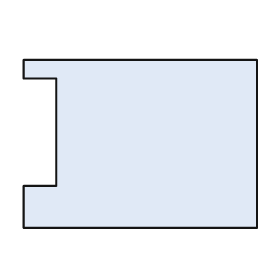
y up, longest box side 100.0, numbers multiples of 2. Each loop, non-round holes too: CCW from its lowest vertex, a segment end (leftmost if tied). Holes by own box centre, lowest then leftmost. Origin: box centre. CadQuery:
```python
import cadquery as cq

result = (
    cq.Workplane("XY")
    .moveTo(-50.0, -36.0)
    .lineTo(50.0, -36.0)
    .lineTo(50.0, 36.0)
    .lineTo(-50.0, 36.0)
    .lineTo(-50.0, 28.0)
    .lineTo(-36.0, 28.0)
    .lineTo(-36.0, -18.0)
    .lineTo(-50.0, -18.0)
    .close()
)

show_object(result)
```